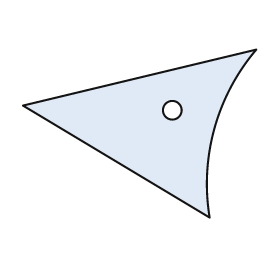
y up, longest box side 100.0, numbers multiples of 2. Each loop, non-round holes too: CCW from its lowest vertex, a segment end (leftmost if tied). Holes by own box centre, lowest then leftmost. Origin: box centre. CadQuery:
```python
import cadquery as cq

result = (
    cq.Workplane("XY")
    .moveTo(30.0, -36.0)
    .threePointArc((32.0, 2.0), (50.0, 36.0))
    .lineTo(-50.0, 12.0)
    .close()
    .moveTo(14.0, 10.0)
    .circle(4.0)
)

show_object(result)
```